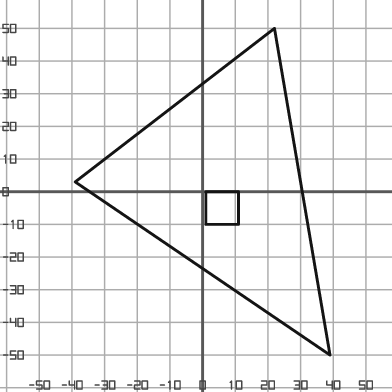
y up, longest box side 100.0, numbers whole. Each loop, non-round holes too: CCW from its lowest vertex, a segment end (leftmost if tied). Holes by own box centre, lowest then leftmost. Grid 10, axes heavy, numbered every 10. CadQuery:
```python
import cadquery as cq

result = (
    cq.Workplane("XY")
    .moveTo(39.0, -50.0)
    .lineTo(22.0, 50.0)
    .lineTo(-39.0, 3.0)
    .close()
    .moveTo(1.0, -10.0)
    .lineTo(11.0, -10.0)
    .lineTo(11.0, 0.0)
    .lineTo(1.0, 0.0)
    .close()
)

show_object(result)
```